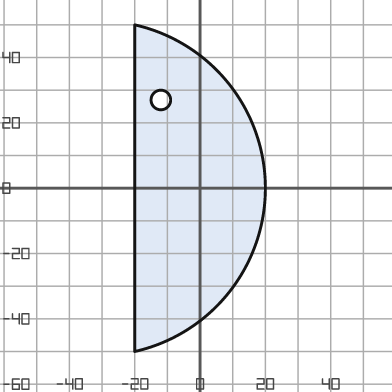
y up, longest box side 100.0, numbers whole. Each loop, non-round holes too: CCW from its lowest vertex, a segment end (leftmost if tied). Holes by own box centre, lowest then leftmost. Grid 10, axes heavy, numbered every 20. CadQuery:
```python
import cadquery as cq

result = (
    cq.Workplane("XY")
    .moveTo(-20.0, -50.0)
    .threePointArc((20.0, 0.0), (-20.0, 50.0))
    .close()
    .moveTo(-12.0, 27.0)
    .circle(3.0)
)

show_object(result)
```